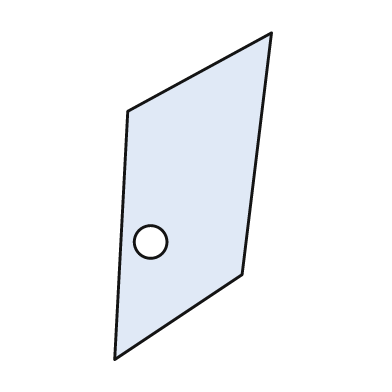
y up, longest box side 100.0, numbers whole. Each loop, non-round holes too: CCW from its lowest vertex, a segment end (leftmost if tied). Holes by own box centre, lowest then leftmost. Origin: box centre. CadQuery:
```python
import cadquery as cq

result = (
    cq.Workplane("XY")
    .moveTo(-24.0, -50.0)
    .lineTo(15.0, -24.0)
    .lineTo(24.0, 50.0)
    .lineTo(-20.0, 26.0)
    .close()
    .moveTo(-13.0, -14.0)
    .circle(5.0)
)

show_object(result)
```